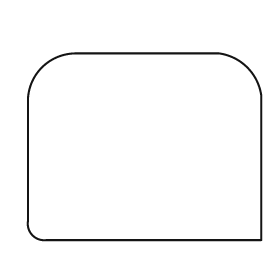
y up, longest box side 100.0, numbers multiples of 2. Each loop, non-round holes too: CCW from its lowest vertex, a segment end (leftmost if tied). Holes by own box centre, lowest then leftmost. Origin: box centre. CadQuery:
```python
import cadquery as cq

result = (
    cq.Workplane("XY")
    .moveTo(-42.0, -40.0)
    .lineTo(50.0, -40.0)
    .lineTo(50.0, 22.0)
    .threePointArc((44.0, 34.0), (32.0, 40.0))
    .lineTo(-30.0, 40.0)
    .threePointArc((-44.0, 34.0), (-50.0, 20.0))
    .lineTo(-50.0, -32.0)
    .threePointArc((-48.0, -38.0), (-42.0, -40.0))
    .close()
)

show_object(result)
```